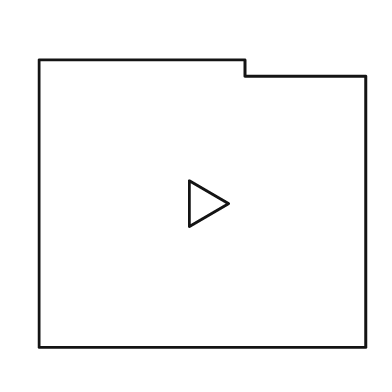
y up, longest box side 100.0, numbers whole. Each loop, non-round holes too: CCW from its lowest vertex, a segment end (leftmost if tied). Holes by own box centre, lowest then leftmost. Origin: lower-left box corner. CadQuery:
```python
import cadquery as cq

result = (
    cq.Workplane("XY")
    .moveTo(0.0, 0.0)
    .lineTo(100.0, 0.0)
    .lineTo(100.0, 83.0)
    .lineTo(63.0, 83.0)
    .lineTo(63.0, 88.0)
    .lineTo(0.0, 88.0)
    .close()
    .moveTo(46.0, 37.0)
    .lineTo(58.0, 44.0)
    .lineTo(46.0, 51.0)
    .close()
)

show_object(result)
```